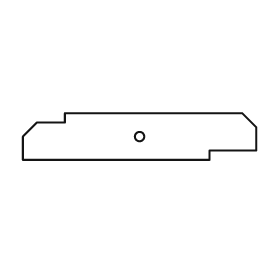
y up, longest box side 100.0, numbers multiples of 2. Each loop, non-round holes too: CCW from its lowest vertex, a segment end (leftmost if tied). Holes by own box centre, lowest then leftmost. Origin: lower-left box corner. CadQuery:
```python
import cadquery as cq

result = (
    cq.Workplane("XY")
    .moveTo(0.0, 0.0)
    .lineTo(80.0, 0.0)
    .lineTo(80.0, 4.0)
    .lineTo(100.0, 4.0)
    .lineTo(100.0, 14.0)
    .lineTo(94.0, 20.0)
    .lineTo(18.0, 20.0)
    .lineTo(18.0, 16.0)
    .lineTo(6.0, 16.0)
    .lineTo(0.0, 10.0)
    .close()
    .moveTo(50.0, 10.0)
    .circle(2.0)
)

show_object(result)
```